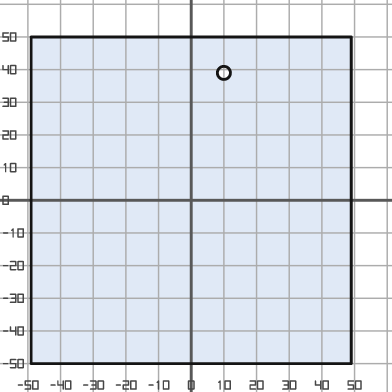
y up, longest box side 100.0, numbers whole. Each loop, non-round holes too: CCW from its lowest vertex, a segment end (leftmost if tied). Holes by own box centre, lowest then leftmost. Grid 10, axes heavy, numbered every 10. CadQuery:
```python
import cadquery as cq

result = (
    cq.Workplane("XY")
    .moveTo(-49.0, -50.0)
    .lineTo(49.0, -50.0)
    .lineTo(49.0, 50.0)
    .lineTo(-49.0, 50.0)
    .close()
    .moveTo(10.0, 39.0)
    .circle(2.0)
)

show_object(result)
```